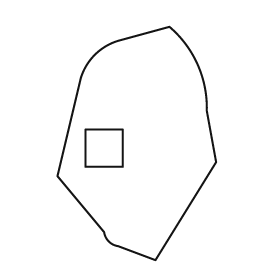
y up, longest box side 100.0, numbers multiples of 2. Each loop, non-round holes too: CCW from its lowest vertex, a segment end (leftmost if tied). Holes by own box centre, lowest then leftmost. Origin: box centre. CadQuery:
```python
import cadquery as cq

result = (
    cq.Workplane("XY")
    .moveTo(8.0, -50.0)
    .lineTo(34.0, -8.0)
    .lineTo(30.0, 14.0)
    .threePointArc((26.0, 34.0), (14.0, 50.0))
    .lineTo(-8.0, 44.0)
    .threePointArc((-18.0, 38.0), (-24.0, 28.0))
    .lineTo(-34.0, -14.0)
    .lineTo(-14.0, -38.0)
    .threePointArc((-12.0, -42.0), (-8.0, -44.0))
    .close()
    .moveTo(-22.0, -10.0)
    .lineTo(-6.0, -10.0)
    .lineTo(-6.0, 6.0)
    .lineTo(-22.0, 6.0)
    .close()
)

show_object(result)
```